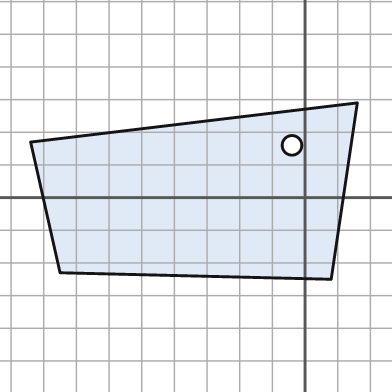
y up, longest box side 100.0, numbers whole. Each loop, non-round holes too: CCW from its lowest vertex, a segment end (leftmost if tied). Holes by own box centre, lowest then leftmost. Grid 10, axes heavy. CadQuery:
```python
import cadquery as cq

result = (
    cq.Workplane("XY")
    .moveTo(8.0, -25.0)
    .lineTo(16.0, 29.0)
    .lineTo(-84.0, 17.0)
    .lineTo(-75.0, -23.0)
    .close()
    .moveTo(-4.0, 16.0)
    .circle(3.0)
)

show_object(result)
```